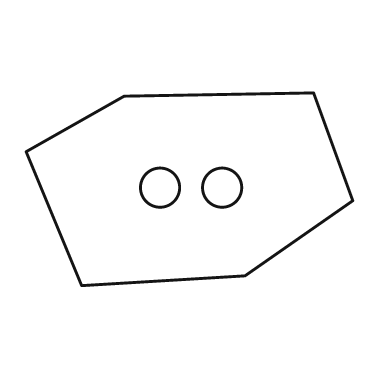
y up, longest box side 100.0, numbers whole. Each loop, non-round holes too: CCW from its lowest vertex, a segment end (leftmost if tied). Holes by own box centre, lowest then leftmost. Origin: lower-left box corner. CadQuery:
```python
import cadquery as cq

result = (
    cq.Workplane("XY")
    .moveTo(17.0, 0.0)
    .lineTo(67.0, 3.0)
    .lineTo(100.0, 26.0)
    .lineTo(88.0, 59.0)
    .lineTo(30.0, 58.0)
    .lineTo(0.0, 41.0)
    .close()
    .moveTo(41.0, 30.0)
    .circle(6.0)
    .moveTo(60.0, 30.0)
    .circle(6.0)
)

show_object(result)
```